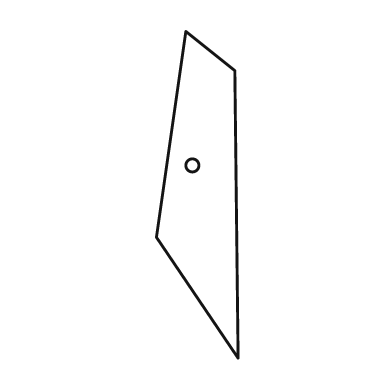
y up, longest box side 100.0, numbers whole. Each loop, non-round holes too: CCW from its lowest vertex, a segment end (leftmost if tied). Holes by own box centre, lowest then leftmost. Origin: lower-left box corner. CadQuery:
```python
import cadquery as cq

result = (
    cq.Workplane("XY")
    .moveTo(25.0, 0.0)
    .lineTo(24.0, 88.0)
    .lineTo(9.0, 100.0)
    .lineTo(0.0, 37.0)
    .close()
    .moveTo(11.0, 59.0)
    .circle(2.0)
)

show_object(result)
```